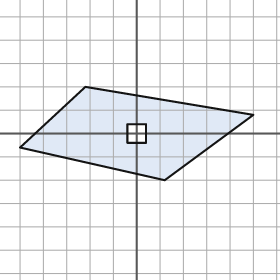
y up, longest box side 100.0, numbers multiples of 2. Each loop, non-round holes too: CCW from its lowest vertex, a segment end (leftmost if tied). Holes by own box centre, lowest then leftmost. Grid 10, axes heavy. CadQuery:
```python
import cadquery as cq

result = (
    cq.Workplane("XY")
    .moveTo(12.0, -20.0)
    .lineTo(50.0, 8.0)
    .lineTo(-22.0, 20.0)
    .lineTo(-50.0, -6.0)
    .close()
    .moveTo(-4.0, -4.0)
    .lineTo(4.0, -4.0)
    .lineTo(4.0, 4.0)
    .lineTo(-4.0, 4.0)
    .close()
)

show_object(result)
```